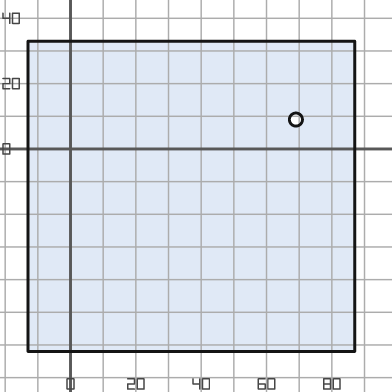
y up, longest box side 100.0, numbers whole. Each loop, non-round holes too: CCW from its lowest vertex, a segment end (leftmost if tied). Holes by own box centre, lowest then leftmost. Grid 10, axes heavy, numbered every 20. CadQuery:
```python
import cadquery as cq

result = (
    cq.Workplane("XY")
    .moveTo(-13.0, -62.0)
    .lineTo(87.0, -62.0)
    .lineTo(87.0, 33.0)
    .lineTo(-13.0, 33.0)
    .close()
    .moveTo(69.0, 9.0)
    .circle(2.0)
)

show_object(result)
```